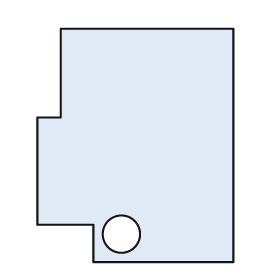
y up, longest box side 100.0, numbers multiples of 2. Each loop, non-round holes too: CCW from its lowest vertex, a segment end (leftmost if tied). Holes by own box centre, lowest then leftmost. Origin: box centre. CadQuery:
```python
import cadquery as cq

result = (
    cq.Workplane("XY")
    .moveTo(-18.0, -50.0)
    .lineTo(42.0, -50.0)
    .lineTo(42.0, 50.0)
    .lineTo(-32.0, 50.0)
    .lineTo(-32.0, 12.0)
    .lineTo(-42.0, 12.0)
    .lineTo(-42.0, -34.0)
    .lineTo(-18.0, -34.0)
    .close()
    .moveTo(-6.0, -38.0)
    .circle(8.0)
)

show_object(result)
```